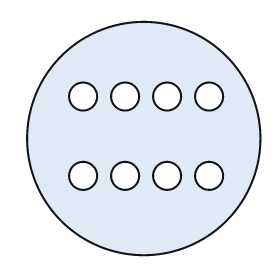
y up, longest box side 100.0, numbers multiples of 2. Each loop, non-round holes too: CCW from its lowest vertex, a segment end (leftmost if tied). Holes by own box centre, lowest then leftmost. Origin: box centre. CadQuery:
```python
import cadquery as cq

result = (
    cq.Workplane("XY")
    .moveTo(0.0, 0.0)
    .circle(50.0)
    .moveTo(-26.0, -16.0)
    .circle(6.0)
    .moveTo(-8.0, -16.0)
    .circle(6.0)
    .moveTo(10.0, -16.0)
    .circle(6.0)
    .moveTo(28.0, -16.0)
    .circle(6.0)
    .moveTo(-26.0, 18.0)
    .circle(6.0)
    .moveTo(-8.0, 18.0)
    .circle(6.0)
    .moveTo(10.0, 18.0)
    .circle(6.0)
    .moveTo(28.0, 18.0)
    .circle(6.0)
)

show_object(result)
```